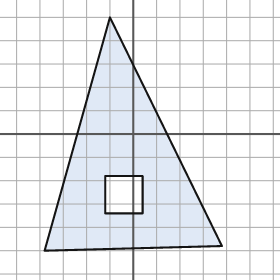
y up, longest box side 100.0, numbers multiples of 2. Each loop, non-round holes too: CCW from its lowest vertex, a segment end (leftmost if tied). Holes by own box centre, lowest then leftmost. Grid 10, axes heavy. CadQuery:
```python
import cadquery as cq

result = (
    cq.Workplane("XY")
    .moveTo(-38.0, -50.0)
    .lineTo(38.0, -48.0)
    .lineTo(-10.0, 50.0)
    .close()
    .moveTo(-12.0, -34.0)
    .lineTo(4.0, -34.0)
    .lineTo(4.0, -18.0)
    .lineTo(-12.0, -18.0)
    .close()
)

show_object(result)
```